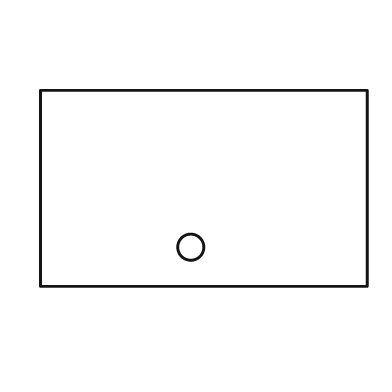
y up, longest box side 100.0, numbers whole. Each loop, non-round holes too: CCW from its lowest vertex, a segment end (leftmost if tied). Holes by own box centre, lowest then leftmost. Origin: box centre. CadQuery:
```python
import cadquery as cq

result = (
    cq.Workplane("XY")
    .moveTo(-50.0, -30.0)
    .lineTo(50.0, -30.0)
    .lineTo(50.0, 30.0)
    .lineTo(-50.0, 30.0)
    .close()
    .moveTo(-4.0, -18.0)
    .circle(4.0)
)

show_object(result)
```